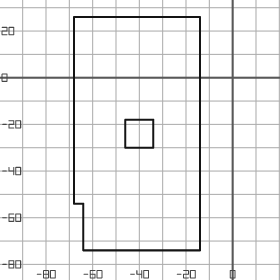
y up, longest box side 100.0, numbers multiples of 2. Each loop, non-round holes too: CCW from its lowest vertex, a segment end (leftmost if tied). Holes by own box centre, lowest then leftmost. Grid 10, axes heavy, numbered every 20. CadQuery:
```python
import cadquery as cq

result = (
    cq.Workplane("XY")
    .moveTo(-64.0, -74.0)
    .lineTo(-14.0, -74.0)
    .lineTo(-14.0, 26.0)
    .lineTo(-68.0, 26.0)
    .lineTo(-68.0, -54.0)
    .lineTo(-64.0, -54.0)
    .close()
    .moveTo(-46.0, -30.0)
    .lineTo(-34.0, -30.0)
    .lineTo(-34.0, -18.0)
    .lineTo(-46.0, -18.0)
    .close()
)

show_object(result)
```